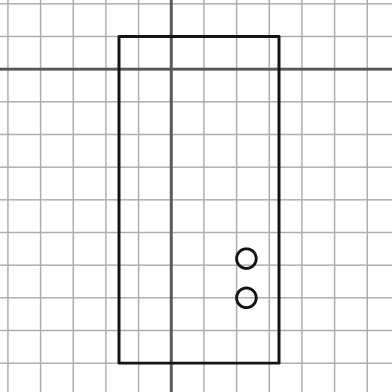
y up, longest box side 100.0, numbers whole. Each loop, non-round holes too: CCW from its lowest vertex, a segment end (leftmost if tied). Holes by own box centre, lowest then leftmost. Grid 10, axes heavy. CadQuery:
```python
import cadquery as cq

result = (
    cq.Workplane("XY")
    .moveTo(-16.0, -90.0)
    .lineTo(33.0, -90.0)
    .lineTo(33.0, 10.0)
    .lineTo(-16.0, 10.0)
    .close()
    .moveTo(23.0, -70.0)
    .circle(3.0)
    .moveTo(23.0, -58.0)
    .circle(3.0)
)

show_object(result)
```